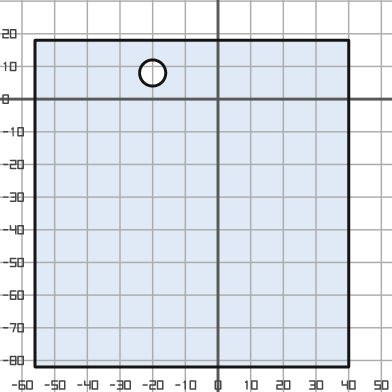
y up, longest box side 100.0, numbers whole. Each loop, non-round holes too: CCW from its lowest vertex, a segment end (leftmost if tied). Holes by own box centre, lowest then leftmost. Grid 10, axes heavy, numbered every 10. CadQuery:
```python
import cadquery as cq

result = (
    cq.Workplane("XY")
    .moveTo(-56.0, -82.0)
    .lineTo(40.0, -82.0)
    .lineTo(40.0, 18.0)
    .lineTo(-56.0, 18.0)
    .close()
    .moveTo(-20.0, 8.0)
    .circle(4.0)
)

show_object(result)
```